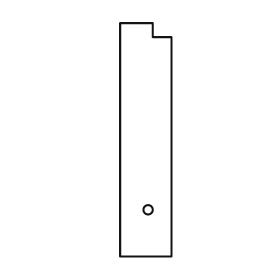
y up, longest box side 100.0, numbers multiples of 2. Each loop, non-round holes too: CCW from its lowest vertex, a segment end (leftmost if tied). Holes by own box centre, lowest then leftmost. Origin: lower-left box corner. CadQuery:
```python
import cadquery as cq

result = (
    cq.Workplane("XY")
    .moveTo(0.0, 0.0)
    .lineTo(22.0, 0.0)
    .lineTo(22.0, 94.0)
    .lineTo(14.0, 94.0)
    .lineTo(14.0, 100.0)
    .lineTo(0.0, 100.0)
    .close()
    .moveTo(12.0, 20.0)
    .circle(2.0)
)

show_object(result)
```